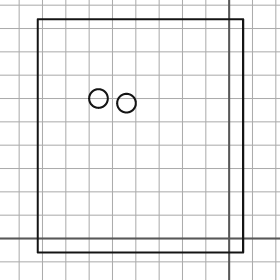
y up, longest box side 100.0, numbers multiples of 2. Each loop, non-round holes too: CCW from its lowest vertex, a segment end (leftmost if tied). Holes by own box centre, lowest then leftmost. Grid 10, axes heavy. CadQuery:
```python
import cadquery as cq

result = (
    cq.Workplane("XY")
    .moveTo(-82.0, -6.0)
    .lineTo(6.0, -6.0)
    .lineTo(6.0, 94.0)
    .lineTo(-82.0, 94.0)
    .close()
    .moveTo(-44.0, 58.0)
    .circle(4.0)
    .moveTo(-56.0, 60.0)
    .circle(4.0)
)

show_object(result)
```